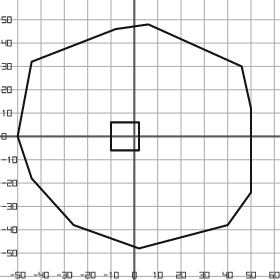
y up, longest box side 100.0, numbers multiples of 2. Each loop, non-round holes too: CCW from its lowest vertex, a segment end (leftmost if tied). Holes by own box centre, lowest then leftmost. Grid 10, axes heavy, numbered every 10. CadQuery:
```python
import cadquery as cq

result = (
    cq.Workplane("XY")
    .moveTo(2.0, -48.0)
    .lineTo(40.0, -38.0)
    .lineTo(50.0, -24.0)
    .lineTo(50.0, 12.0)
    .lineTo(46.0, 30.0)
    .lineTo(6.0, 48.0)
    .lineTo(-8.0, 46.0)
    .lineTo(-44.0, 32.0)
    .lineTo(-50.0, 0.0)
    .lineTo(-44.0, -18.0)
    .lineTo(-26.0, -38.0)
    .close()
    .moveTo(-10.0, -6.0)
    .lineTo(2.0, -6.0)
    .lineTo(2.0, 6.0)
    .lineTo(-10.0, 6.0)
    .close()
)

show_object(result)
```